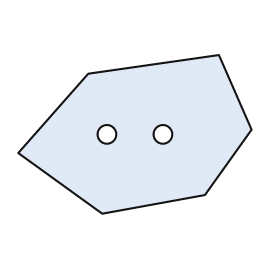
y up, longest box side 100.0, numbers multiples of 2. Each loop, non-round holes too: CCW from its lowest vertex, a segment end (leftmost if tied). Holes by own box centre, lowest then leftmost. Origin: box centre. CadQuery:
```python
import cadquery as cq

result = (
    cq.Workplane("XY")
    .moveTo(-14.0, -34.0)
    .lineTo(30.0, -26.0)
    .lineTo(50.0, 2.0)
    .lineTo(36.0, 34.0)
    .lineTo(-20.0, 26.0)
    .lineTo(-50.0, -8.0)
    .close()
    .moveTo(-12.0, 0.0)
    .circle(4.0)
    .moveTo(12.0, 0.0)
    .circle(4.0)
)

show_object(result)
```